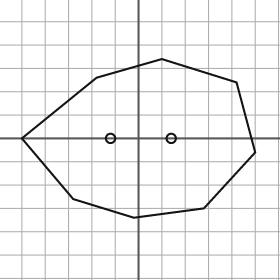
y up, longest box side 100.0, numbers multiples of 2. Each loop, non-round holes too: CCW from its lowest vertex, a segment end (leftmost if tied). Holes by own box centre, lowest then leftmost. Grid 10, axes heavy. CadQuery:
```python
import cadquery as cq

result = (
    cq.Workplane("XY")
    .moveTo(-2.0, -34.0)
    .lineTo(28.0, -30.0)
    .lineTo(50.0, -6.0)
    .lineTo(42.0, 24.0)
    .lineTo(10.0, 34.0)
    .lineTo(-18.0, 26.0)
    .lineTo(-50.0, 0.0)
    .lineTo(-28.0, -26.0)
    .close()
    .moveTo(-12.0, 0.0)
    .circle(2.0)
    .moveTo(14.0, 0.0)
    .circle(2.0)
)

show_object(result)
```